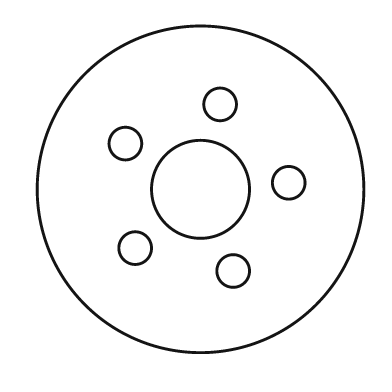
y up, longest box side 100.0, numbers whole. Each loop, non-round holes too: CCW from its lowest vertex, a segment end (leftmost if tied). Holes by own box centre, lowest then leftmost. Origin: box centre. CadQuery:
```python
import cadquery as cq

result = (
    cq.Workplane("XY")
    .moveTo(0.0, 0.0)
    .circle(50.0)
    .moveTo(10.0, -25.0)
    .circle(5.0)
    .moveTo(-20.0, -18.0)
    .circle(5.0)
    .moveTo(0.0, 0.0)
    .circle(15.0)
    .moveTo(27.0, 2.0)
    .circle(5.0)
    .moveTo(-23.0, 14.0)
    .circle(5.0)
    .moveTo(6.0, 26.0)
    .circle(5.0)
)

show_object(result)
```